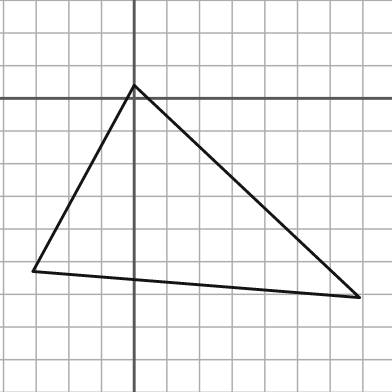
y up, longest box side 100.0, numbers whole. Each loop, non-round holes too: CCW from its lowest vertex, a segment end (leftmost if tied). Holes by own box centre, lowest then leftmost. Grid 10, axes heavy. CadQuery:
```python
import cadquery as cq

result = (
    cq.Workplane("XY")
    .moveTo(69.0, -61.0)
    .lineTo(0.0, 4.0)
    .lineTo(-31.0, -53.0)
    .close()
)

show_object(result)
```